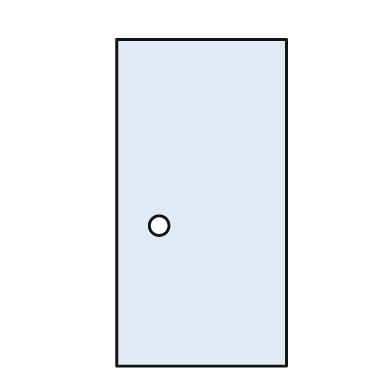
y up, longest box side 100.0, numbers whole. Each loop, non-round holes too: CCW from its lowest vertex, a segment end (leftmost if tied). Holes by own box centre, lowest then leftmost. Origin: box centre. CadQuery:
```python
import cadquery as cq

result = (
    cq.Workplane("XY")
    .moveTo(-26.0, -50.0)
    .lineTo(26.0, -50.0)
    .lineTo(26.0, 50.0)
    .lineTo(-26.0, 50.0)
    .close()
    .moveTo(-13.0, -7.0)
    .circle(3.0)
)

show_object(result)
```